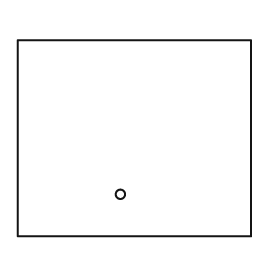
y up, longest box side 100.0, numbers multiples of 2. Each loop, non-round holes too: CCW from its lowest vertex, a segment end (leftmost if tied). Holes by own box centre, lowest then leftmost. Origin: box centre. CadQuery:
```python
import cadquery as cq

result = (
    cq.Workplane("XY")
    .moveTo(-50.0, -42.0)
    .lineTo(50.0, -42.0)
    .lineTo(50.0, 42.0)
    .lineTo(-50.0, 42.0)
    .close()
    .moveTo(-6.0, -24.0)
    .circle(2.0)
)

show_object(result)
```